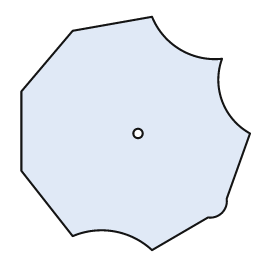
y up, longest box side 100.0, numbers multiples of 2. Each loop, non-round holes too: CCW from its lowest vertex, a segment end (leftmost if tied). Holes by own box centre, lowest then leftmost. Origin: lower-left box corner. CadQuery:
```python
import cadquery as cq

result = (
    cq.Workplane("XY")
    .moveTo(56.0, 0.0)
    .lineTo(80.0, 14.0)
    .threePointArc((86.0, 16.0), (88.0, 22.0))
    .lineTo(98.0, 50.0)
    .threePointArc((86.0, 64.0), (86.0, 82.0))
    .threePointArc((68.0, 86.0), (56.0, 100.0))
    .lineTo(22.0, 94.0)
    .lineTo(0.0, 68.0)
    .lineTo(0.0, 34.0)
    .lineTo(22.0, 6.0)
    .threePointArc((40.0, 8.0), (56.0, 0.0))
    .close()
    .moveTo(50.0, 50.0)
    .circle(2.0)
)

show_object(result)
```